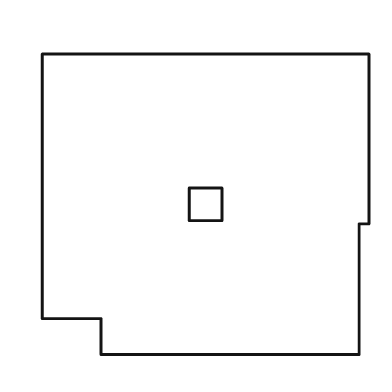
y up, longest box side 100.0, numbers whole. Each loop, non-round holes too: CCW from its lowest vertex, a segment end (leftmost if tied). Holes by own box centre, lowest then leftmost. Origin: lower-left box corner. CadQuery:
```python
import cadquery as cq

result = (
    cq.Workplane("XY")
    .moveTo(18.0, 0.0)
    .lineTo(97.0, 0.0)
    .lineTo(97.0, 40.0)
    .lineTo(100.0, 40.0)
    .lineTo(100.0, 92.0)
    .lineTo(0.0, 92.0)
    .lineTo(0.0, 11.0)
    .lineTo(18.0, 11.0)
    .close()
    .moveTo(45.0, 41.0)
    .lineTo(55.0, 41.0)
    .lineTo(55.0, 51.0)
    .lineTo(45.0, 51.0)
    .close()
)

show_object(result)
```